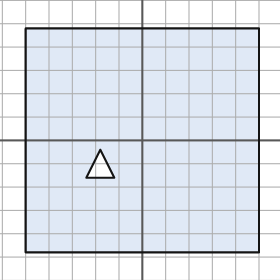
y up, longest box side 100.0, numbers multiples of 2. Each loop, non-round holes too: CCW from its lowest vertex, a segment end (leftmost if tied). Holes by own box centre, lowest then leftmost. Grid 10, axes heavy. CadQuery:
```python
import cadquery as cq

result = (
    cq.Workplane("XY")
    .moveTo(-50.0, -48.0)
    .lineTo(50.0, -48.0)
    .lineTo(50.0, 48.0)
    .lineTo(-50.0, 48.0)
    .close()
    .moveTo(-24.0, -16.0)
    .lineTo(-12.0, -16.0)
    .lineTo(-18.0, -4.0)
    .close()
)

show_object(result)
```